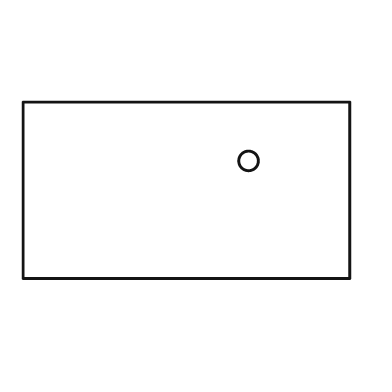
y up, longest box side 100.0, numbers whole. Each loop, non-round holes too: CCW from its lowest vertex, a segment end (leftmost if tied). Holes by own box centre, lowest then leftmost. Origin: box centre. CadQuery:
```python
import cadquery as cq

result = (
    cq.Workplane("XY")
    .moveTo(-50.0, -27.0)
    .lineTo(50.0, -27.0)
    .lineTo(50.0, 27.0)
    .lineTo(-50.0, 27.0)
    .close()
    .moveTo(19.0, 9.0)
    .circle(3.0)
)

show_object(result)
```